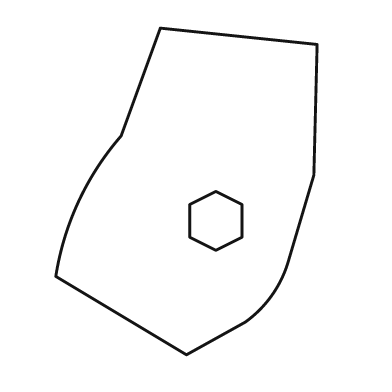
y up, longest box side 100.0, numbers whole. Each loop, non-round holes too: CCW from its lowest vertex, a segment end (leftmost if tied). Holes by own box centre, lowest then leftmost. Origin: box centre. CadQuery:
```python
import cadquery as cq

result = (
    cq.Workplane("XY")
    .moveTo(0.0, -50.0)
    .lineTo(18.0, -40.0)
    .threePointArc((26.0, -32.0), (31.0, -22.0))
    .lineTo(39.0, 5.0)
    .lineTo(40.0, 45.0)
    .lineTo(-8.0, 50.0)
    .lineTo(-20.0, 17.0)
    .threePointArc((-33.0, -3.0), (-40.0, -26.0))
    .close()
    .moveTo(9.0, -18.0)
    .lineTo(17.0, -14.0)
    .lineTo(17.0, -4.0)
    .lineTo(9.0, 0.0)
    .lineTo(1.0, -4.0)
    .lineTo(1.0, -14.0)
    .close()
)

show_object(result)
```